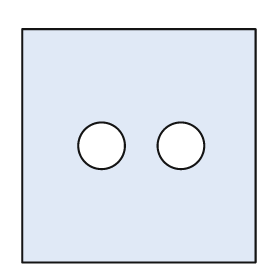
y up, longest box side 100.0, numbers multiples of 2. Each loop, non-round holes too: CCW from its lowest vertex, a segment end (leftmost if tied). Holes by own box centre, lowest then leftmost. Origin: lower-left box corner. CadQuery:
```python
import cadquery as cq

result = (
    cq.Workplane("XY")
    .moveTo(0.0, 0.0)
    .lineTo(100.0, 0.0)
    .lineTo(100.0, 100.0)
    .lineTo(0.0, 100.0)
    .close()
    .moveTo(34.0, 50.0)
    .circle(10.0)
    .moveTo(68.0, 50.0)
    .circle(10.0)
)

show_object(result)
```